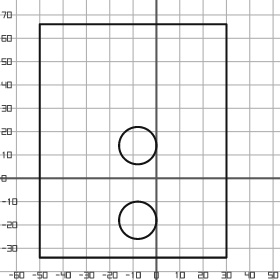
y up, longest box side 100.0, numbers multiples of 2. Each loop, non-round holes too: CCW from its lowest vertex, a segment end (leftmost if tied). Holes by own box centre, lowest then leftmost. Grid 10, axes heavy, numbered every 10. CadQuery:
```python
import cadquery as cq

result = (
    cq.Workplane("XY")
    .moveTo(-50.0, -34.0)
    .lineTo(30.0, -34.0)
    .lineTo(30.0, 66.0)
    .lineTo(-50.0, 66.0)
    .close()
    .moveTo(-8.0, -18.0)
    .circle(8.0)
    .moveTo(-8.0, 14.0)
    .circle(8.0)
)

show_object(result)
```